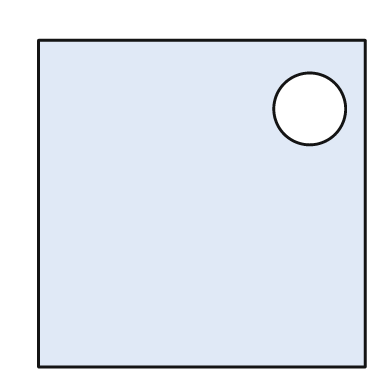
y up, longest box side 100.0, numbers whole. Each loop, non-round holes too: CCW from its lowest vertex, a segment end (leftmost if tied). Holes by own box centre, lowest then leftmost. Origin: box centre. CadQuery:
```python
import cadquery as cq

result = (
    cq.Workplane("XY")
    .moveTo(-50.0, -50.0)
    .lineTo(50.0, -50.0)
    .lineTo(50.0, 50.0)
    .lineTo(-50.0, 50.0)
    .close()
    .moveTo(33.0, 29.0)
    .circle(11.0)
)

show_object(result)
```